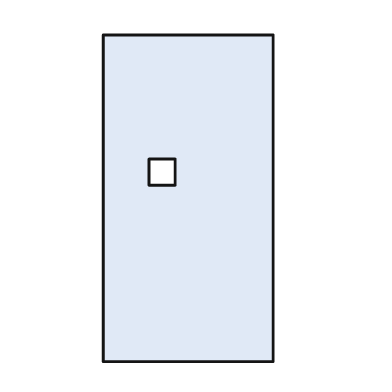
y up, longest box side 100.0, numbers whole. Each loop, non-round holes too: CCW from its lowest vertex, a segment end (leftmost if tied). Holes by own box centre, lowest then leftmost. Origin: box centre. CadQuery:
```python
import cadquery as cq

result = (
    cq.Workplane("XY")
    .moveTo(-26.0, -50.0)
    .lineTo(26.0, -50.0)
    .lineTo(26.0, 50.0)
    .lineTo(-26.0, 50.0)
    .close()
    .moveTo(-12.0, 4.0)
    .lineTo(-4.0, 4.0)
    .lineTo(-4.0, 12.0)
    .lineTo(-12.0, 12.0)
    .close()
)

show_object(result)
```